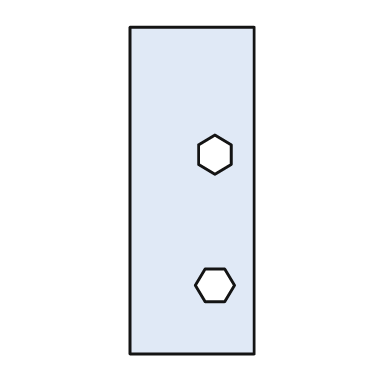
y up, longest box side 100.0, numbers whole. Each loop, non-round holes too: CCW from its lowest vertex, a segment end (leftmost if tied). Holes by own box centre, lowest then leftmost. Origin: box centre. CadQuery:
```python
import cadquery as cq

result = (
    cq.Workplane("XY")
    .moveTo(-19.0, -50.0)
    .lineTo(19.0, -50.0)
    .lineTo(19.0, 50.0)
    .lineTo(-19.0, 50.0)
    .close()
    .moveTo(4.0, -34.0)
    .lineTo(10.0, -34.0)
    .lineTo(13.0, -29.0)
    .lineTo(10.0, -24.0)
    .lineTo(4.0, -24.0)
    .lineTo(1.0, -29.0)
    .close()
    .moveTo(7.0, 5.0)
    .lineTo(12.0, 8.0)
    .lineTo(12.0, 14.0)
    .lineTo(7.0, 17.0)
    .lineTo(2.0, 14.0)
    .lineTo(2.0, 8.0)
    .close()
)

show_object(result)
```